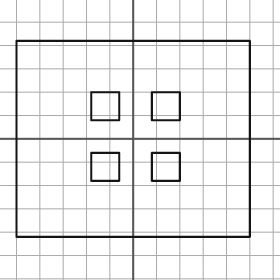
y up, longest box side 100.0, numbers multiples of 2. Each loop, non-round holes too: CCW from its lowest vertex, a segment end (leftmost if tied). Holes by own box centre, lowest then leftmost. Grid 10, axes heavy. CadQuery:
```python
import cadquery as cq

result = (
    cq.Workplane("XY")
    .moveTo(-50.0, -42.0)
    .lineTo(50.0, -42.0)
    .lineTo(50.0, 42.0)
    .lineTo(-50.0, 42.0)
    .close()
    .moveTo(-18.0, -18.0)
    .lineTo(-6.0, -18.0)
    .lineTo(-6.0, -6.0)
    .lineTo(-18.0, -6.0)
    .close()
    .moveTo(8.0, -18.0)
    .lineTo(20.0, -18.0)
    .lineTo(20.0, -6.0)
    .lineTo(8.0, -6.0)
    .close()
    .moveTo(-18.0, 8.0)
    .lineTo(-6.0, 8.0)
    .lineTo(-6.0, 20.0)
    .lineTo(-18.0, 20.0)
    .close()
    .moveTo(8.0, 8.0)
    .lineTo(20.0, 8.0)
    .lineTo(20.0, 20.0)
    .lineTo(8.0, 20.0)
    .close()
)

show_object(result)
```